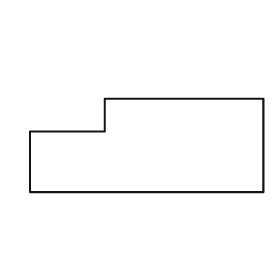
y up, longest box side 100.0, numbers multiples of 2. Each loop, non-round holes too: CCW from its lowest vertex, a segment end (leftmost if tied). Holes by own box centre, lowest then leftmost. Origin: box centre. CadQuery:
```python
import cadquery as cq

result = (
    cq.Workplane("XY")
    .moveTo(-50.0, -20.0)
    .lineTo(50.0, -20.0)
    .lineTo(50.0, 20.0)
    .lineTo(-18.0, 20.0)
    .lineTo(-18.0, 6.0)
    .lineTo(-50.0, 6.0)
    .close()
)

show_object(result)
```